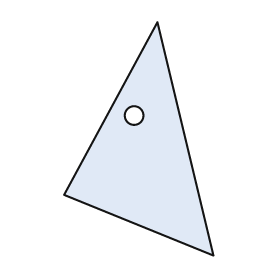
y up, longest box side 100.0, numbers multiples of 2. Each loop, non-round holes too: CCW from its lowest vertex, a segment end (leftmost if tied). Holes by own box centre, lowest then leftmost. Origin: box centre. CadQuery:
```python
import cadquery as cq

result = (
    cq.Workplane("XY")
    .moveTo(32.0, -50.0)
    .lineTo(8.0, 50.0)
    .lineTo(-32.0, -24.0)
    .close()
    .moveTo(-2.0, 10.0)
    .circle(4.0)
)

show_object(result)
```